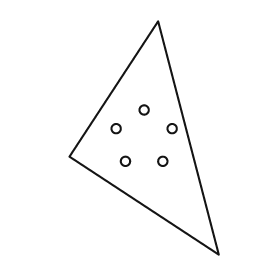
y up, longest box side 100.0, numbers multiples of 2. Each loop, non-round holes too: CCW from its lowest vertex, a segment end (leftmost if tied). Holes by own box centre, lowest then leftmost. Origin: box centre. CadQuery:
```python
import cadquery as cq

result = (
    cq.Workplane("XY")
    .moveTo(32.0, -50.0)
    .lineTo(6.0, 50.0)
    .lineTo(-32.0, -8.0)
    .close()
    .moveTo(-8.0, -10.0)
    .circle(2.0)
    .moveTo(8.0, -10.0)
    .circle(2.0)
    .moveTo(-12.0, 4.0)
    .circle(2.0)
    .moveTo(12.0, 4.0)
    .circle(2.0)
    .moveTo(0.0, 12.0)
    .circle(2.0)
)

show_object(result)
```